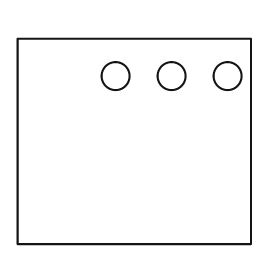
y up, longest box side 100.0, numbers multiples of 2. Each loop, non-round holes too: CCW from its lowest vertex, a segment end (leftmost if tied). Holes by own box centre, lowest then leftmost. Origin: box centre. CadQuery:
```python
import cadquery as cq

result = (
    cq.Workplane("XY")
    .moveTo(-50.0, -44.0)
    .lineTo(50.0, -44.0)
    .lineTo(50.0, 44.0)
    .lineTo(-50.0, 44.0)
    .close()
    .moveTo(-8.0, 28.0)
    .circle(6.0)
    .moveTo(16.0, 28.0)
    .circle(6.0)
    .moveTo(40.0, 28.0)
    .circle(6.0)
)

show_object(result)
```